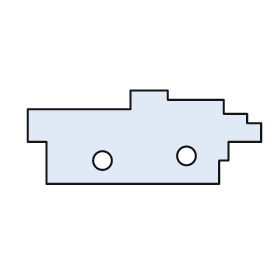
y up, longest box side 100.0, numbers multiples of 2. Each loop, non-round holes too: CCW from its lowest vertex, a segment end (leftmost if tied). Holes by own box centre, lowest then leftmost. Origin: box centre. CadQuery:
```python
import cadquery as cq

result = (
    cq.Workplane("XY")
    .moveTo(-42.0, -20.0)
    .lineTo(32.0, -20.0)
    .lineTo(32.0, -10.0)
    .lineTo(36.0, -10.0)
    .lineTo(36.0, -2.0)
    .lineTo(50.0, -2.0)
    .lineTo(50.0, 6.0)
    .lineTo(44.0, 6.0)
    .lineTo(44.0, 10.0)
    .lineTo(34.0, 10.0)
    .lineTo(34.0, 16.0)
    .lineTo(10.0, 16.0)
    .lineTo(10.0, 20.0)
    .lineTo(-6.0, 20.0)
    .lineTo(-6.0, 12.0)
    .lineTo(-50.0, 12.0)
    .lineTo(-50.0, -2.0)
    .lineTo(-42.0, -2.0)
    .close()
    .moveTo(-18.0, -10.0)
    .circle(4.0)
    .moveTo(18.0, -8.0)
    .circle(4.0)
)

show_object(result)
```